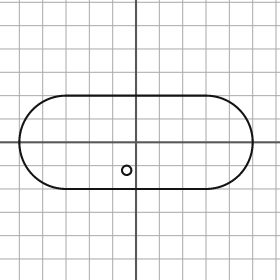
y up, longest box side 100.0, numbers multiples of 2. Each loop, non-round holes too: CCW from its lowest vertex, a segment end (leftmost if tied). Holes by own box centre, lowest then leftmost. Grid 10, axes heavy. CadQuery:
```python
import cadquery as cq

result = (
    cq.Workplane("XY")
    .moveTo(-30.0, -20.0)
    .lineTo(30.0, -20.0)
    .threePointArc((50.0, 0.0), (30.0, 20.0))
    .lineTo(-30.0, 20.0)
    .threePointArc((-50.0, 0.0), (-30.0, -20.0))
    .close()
    .moveTo(-4.0, -12.0)
    .circle(2.0)
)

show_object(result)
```